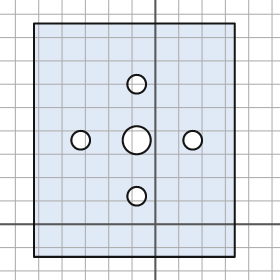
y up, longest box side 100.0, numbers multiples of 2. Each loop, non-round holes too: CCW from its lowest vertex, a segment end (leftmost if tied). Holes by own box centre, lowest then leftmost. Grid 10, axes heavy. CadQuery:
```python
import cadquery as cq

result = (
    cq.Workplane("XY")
    .moveTo(-52.0, -14.0)
    .lineTo(34.0, -14.0)
    .lineTo(34.0, 86.0)
    .lineTo(-52.0, 86.0)
    .close()
    .moveTo(-8.0, 12.0)
    .circle(4.0)
    .moveTo(-32.0, 36.0)
    .circle(4.0)
    .moveTo(-8.0, 36.0)
    .circle(6.0)
    .moveTo(16.0, 36.0)
    .circle(4.0)
    .moveTo(-8.0, 60.0)
    .circle(4.0)
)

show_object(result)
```